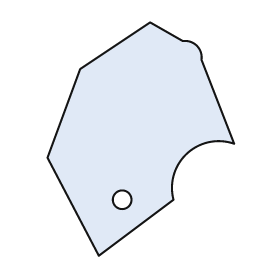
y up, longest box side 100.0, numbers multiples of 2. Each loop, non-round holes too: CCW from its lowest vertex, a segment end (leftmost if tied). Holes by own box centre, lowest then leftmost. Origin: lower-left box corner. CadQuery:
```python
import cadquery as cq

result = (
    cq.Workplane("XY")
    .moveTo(22.0, 0.0)
    .lineTo(54.0, 24.0)
    .threePointArc((60.0, 44.0), (80.0, 48.0))
    .lineTo(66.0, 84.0)
    .threePointArc((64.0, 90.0), (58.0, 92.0))
    .lineTo(44.0, 100.0)
    .lineTo(14.0, 80.0)
    .lineTo(0.0, 42.0)
    .close()
    .moveTo(32.0, 24.0)
    .circle(4.0)
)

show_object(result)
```